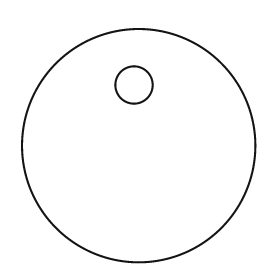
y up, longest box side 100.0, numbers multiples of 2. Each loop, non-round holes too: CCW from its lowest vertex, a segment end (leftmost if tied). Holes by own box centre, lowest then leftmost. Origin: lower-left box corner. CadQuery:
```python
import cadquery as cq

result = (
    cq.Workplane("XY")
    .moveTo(50.0, 50.0)
    .circle(50.0)
    .moveTo(48.0, 76.0)
    .circle(8.0)
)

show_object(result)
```